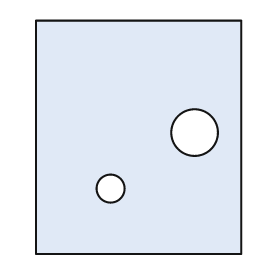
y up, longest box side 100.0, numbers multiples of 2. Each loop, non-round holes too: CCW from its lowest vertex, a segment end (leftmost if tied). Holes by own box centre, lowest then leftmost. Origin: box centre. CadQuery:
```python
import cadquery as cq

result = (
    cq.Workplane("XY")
    .moveTo(-44.0, -50.0)
    .lineTo(44.0, -50.0)
    .lineTo(44.0, 50.0)
    .lineTo(-44.0, 50.0)
    .close()
    .moveTo(-12.0, -22.0)
    .circle(6.0)
    .moveTo(24.0, 2.0)
    .circle(10.0)
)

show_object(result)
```